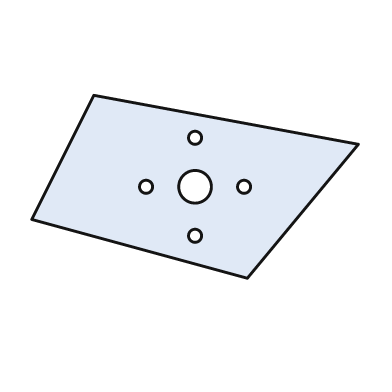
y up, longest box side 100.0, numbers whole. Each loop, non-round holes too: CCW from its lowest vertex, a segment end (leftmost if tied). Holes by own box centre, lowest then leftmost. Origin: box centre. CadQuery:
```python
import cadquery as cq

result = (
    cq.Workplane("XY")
    .moveTo(16.0, -28.0)
    .lineTo(50.0, 13.0)
    .lineTo(-31.0, 28.0)
    .lineTo(-50.0, -10.0)
    .close()
    .moveTo(0.0, -15.0)
    .circle(2.0)
    .moveTo(-15.0, 0.0)
    .circle(2.0)
    .moveTo(0.0, 0.0)
    .circle(5.0)
    .moveTo(15.0, 0.0)
    .circle(2.0)
    .moveTo(0.0, 15.0)
    .circle(2.0)
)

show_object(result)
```